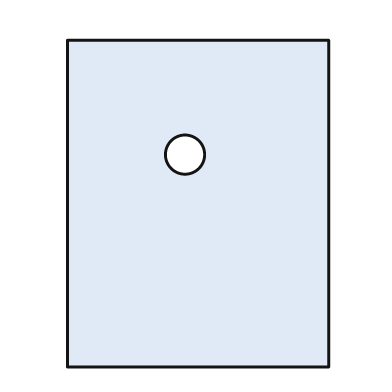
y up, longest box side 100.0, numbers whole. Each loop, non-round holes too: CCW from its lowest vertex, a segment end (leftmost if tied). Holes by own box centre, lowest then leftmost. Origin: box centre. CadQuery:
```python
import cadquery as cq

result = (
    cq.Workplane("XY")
    .moveTo(-40.0, -50.0)
    .lineTo(40.0, -50.0)
    .lineTo(40.0, 50.0)
    .lineTo(-40.0, 50.0)
    .close()
    .moveTo(-4.0, 15.0)
    .circle(6.0)
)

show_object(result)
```